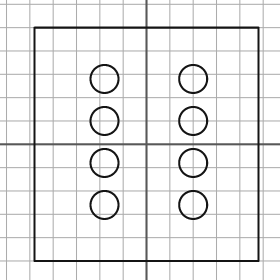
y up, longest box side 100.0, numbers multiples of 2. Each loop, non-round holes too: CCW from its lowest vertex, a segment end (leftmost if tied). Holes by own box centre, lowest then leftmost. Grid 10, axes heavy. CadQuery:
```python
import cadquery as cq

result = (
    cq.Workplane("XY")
    .moveTo(-48.0, -50.0)
    .lineTo(48.0, -50.0)
    .lineTo(48.0, 50.0)
    .lineTo(-48.0, 50.0)
    .close()
    .moveTo(-18.0, -26.0)
    .circle(6.0)
    .moveTo(20.0, -26.0)
    .circle(6.0)
    .moveTo(-18.0, -8.0)
    .circle(6.0)
    .moveTo(20.0, -8.0)
    .circle(6.0)
    .moveTo(-18.0, 10.0)
    .circle(6.0)
    .moveTo(20.0, 10.0)
    .circle(6.0)
    .moveTo(-18.0, 28.0)
    .circle(6.0)
    .moveTo(20.0, 28.0)
    .circle(6.0)
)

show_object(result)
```